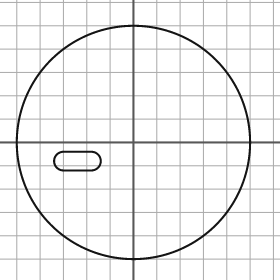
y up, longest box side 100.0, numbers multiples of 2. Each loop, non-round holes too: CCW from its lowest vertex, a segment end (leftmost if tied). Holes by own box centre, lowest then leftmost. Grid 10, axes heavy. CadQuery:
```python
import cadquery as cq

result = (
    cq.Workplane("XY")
    .moveTo(0.0, 0.0)
    .circle(50.0)
    .moveTo(-30.0, -12.0)
    .lineTo(-18.0, -12.0)
    .threePointArc((-14.0, -8.0), (-18.0, -4.0))
    .lineTo(-30.0, -4.0)
    .threePointArc((-34.0, -8.0), (-30.0, -12.0))
    .close()
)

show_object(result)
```